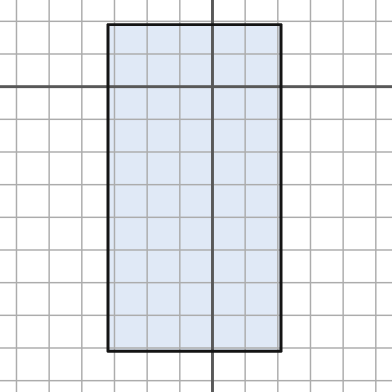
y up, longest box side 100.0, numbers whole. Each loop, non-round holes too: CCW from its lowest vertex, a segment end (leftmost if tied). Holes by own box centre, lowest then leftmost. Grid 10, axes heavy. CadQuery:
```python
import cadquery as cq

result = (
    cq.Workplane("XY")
    .moveTo(-32.0, -81.0)
    .lineTo(21.0, -81.0)
    .lineTo(21.0, 19.0)
    .lineTo(-32.0, 19.0)
    .close()
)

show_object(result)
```